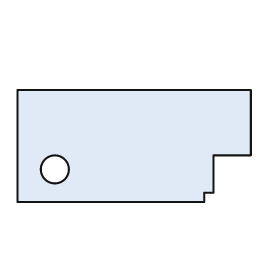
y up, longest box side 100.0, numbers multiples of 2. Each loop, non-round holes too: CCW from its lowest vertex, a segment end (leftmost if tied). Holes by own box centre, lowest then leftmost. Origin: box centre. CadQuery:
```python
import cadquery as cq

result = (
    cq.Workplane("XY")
    .moveTo(-50.0, -24.0)
    .lineTo(30.0, -24.0)
    .lineTo(30.0, -20.0)
    .lineTo(34.0, -20.0)
    .lineTo(34.0, -4.0)
    .lineTo(50.0, -4.0)
    .lineTo(50.0, 24.0)
    .lineTo(-50.0, 24.0)
    .close()
    .moveTo(-34.0, -10.0)
    .circle(6.0)
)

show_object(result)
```